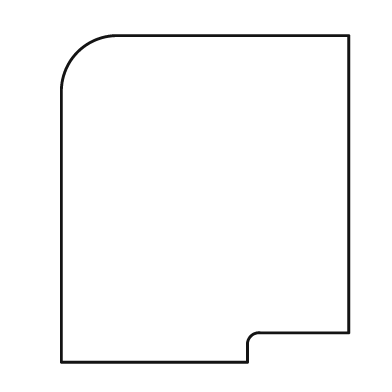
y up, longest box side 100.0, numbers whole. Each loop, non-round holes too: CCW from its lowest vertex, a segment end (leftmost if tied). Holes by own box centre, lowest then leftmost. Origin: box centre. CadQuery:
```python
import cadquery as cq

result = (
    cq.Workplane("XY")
    .moveTo(-44.0, -50.0)
    .lineTo(13.0, -50.0)
    .lineTo(13.0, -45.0)
    .threePointArc((14.0, -42.0), (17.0, -41.0))
    .lineTo(44.0, -41.0)
    .lineTo(44.0, 50.0)
    .lineTo(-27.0, 50.0)
    .threePointArc((-39.0, 45.0), (-44.0, 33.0))
    .close()
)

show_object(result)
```